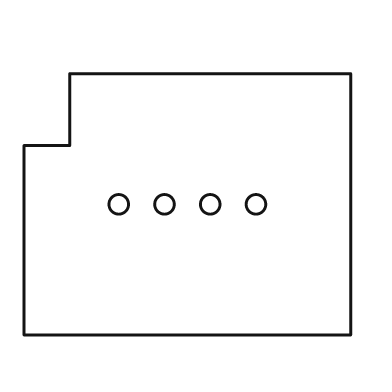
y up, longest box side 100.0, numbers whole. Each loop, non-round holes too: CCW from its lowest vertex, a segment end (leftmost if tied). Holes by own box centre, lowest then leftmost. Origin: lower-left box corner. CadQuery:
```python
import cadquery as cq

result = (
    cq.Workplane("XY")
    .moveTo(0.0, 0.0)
    .lineTo(100.0, 0.0)
    .lineTo(100.0, 80.0)
    .lineTo(14.0, 80.0)
    .lineTo(14.0, 58.0)
    .lineTo(0.0, 58.0)
    .close()
    .moveTo(29.0, 40.0)
    .circle(3.0)
    .moveTo(43.0, 40.0)
    .circle(3.0)
    .moveTo(57.0, 40.0)
    .circle(3.0)
    .moveTo(71.0, 40.0)
    .circle(3.0)
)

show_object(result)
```